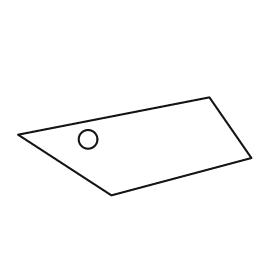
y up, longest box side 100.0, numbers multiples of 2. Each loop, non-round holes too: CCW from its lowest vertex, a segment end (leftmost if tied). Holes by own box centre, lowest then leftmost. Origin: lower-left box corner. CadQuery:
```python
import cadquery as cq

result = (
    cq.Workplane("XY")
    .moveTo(40.0, 0.0)
    .lineTo(100.0, 16.0)
    .lineTo(82.0, 42.0)
    .lineTo(0.0, 26.0)
    .close()
    .moveTo(30.0, 24.0)
    .circle(4.0)
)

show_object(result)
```